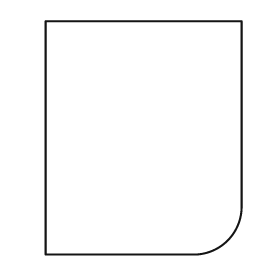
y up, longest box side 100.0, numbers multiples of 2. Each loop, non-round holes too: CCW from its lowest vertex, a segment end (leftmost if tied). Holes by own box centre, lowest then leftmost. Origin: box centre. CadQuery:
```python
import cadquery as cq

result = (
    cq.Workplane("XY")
    .moveTo(-42.0, -50.0)
    .lineTo(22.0, -50.0)
    .threePointArc((36.0, -44.0), (42.0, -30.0))
    .lineTo(42.0, 50.0)
    .lineTo(-42.0, 50.0)
    .close()
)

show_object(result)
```